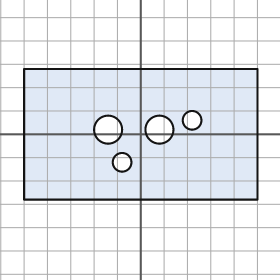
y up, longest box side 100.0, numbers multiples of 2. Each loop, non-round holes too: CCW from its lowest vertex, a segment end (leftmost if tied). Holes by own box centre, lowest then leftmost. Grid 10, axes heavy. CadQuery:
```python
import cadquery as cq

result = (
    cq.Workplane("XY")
    .moveTo(-50.0, -28.0)
    .lineTo(50.0, -28.0)
    .lineTo(50.0, 28.0)
    .lineTo(-50.0, 28.0)
    .close()
    .moveTo(-8.0, -12.0)
    .circle(4.0)
    .moveTo(-14.0, 2.0)
    .circle(6.0)
    .moveTo(8.0, 2.0)
    .circle(6.0)
    .moveTo(22.0, 6.0)
    .circle(4.0)
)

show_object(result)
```